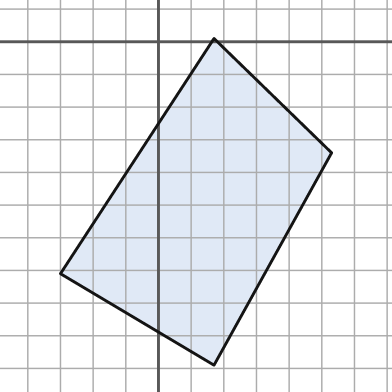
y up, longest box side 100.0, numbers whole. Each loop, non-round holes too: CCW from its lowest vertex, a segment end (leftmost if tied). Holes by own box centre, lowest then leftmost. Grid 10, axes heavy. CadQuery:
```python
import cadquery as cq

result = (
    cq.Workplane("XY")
    .moveTo(17.0, -99.0)
    .lineTo(53.0, -34.0)
    .lineTo(17.0, 1.0)
    .lineTo(-30.0, -71.0)
    .close()
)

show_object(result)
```